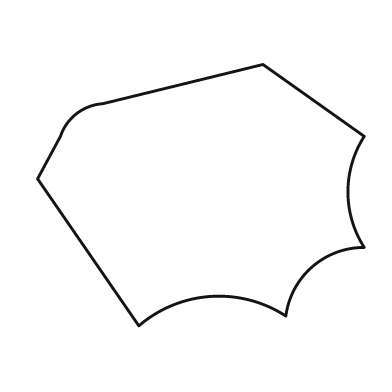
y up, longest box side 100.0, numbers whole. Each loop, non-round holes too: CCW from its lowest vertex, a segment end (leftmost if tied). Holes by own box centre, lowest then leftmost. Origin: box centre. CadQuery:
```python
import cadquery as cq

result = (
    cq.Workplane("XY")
    .moveTo(-19.0, -40.0)
    .threePointArc((3.0, -31.0), (26.0, -37.0))
    .threePointArc((34.0, -22.0), (50.0, -16.0))
    .threePointArc((45.0, 1.0), (50.0, 18.0))
    .lineTo(19.0, 40.0)
    .lineTo(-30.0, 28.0)
    .threePointArc((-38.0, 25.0), (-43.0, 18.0))
    .lineTo(-50.0, 5.0)
    .close()
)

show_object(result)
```